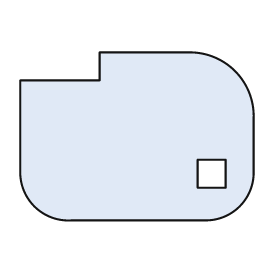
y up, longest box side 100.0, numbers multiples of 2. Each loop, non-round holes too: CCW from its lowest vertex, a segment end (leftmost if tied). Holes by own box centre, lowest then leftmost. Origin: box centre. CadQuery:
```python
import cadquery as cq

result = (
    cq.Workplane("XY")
    .moveTo(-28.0, -36.0)
    .lineTo(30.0, -36.0)
    .threePointArc((44.0, -30.0), (50.0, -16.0))
    .lineTo(50.0, 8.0)
    .threePointArc((42.0, 28.0), (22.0, 36.0))
    .lineTo(-16.0, 36.0)
    .lineTo(-16.0, 24.0)
    .lineTo(-50.0, 24.0)
    .lineTo(-50.0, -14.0)
    .threePointArc((-44.0, -30.0), (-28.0, -36.0))
    .close()
    .moveTo(26.0, -22.0)
    .lineTo(38.0, -22.0)
    .lineTo(38.0, -10.0)
    .lineTo(26.0, -10.0)
    .close()
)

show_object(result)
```